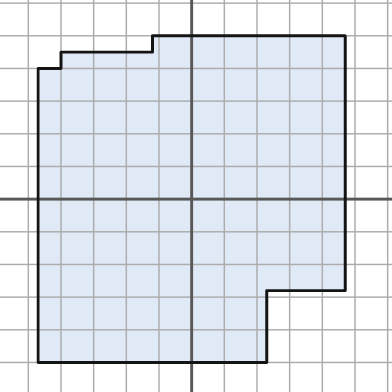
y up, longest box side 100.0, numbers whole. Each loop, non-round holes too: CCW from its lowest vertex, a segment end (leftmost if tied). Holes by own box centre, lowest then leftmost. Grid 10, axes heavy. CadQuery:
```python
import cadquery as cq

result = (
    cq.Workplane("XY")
    .moveTo(-47.0, -50.0)
    .lineTo(23.0, -50.0)
    .lineTo(23.0, -28.0)
    .lineTo(47.0, -28.0)
    .lineTo(47.0, 50.0)
    .lineTo(-12.0, 50.0)
    .lineTo(-12.0, 45.0)
    .lineTo(-40.0, 45.0)
    .lineTo(-40.0, 40.0)
    .lineTo(-47.0, 40.0)
    .close()
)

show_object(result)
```